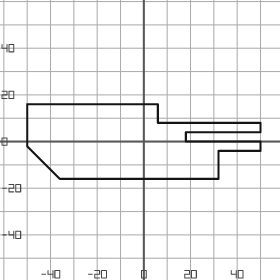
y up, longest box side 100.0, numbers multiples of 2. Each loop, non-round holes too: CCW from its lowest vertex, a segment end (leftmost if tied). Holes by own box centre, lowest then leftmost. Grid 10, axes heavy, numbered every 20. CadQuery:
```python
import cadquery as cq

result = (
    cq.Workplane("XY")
    .moveTo(-36.0, -16.0)
    .lineTo(32.0, -16.0)
    .lineTo(32.0, -4.0)
    .lineTo(50.0, -4.0)
    .lineTo(50.0, 0.0)
    .lineTo(18.0, 0.0)
    .lineTo(18.0, 4.0)
    .lineTo(50.0, 4.0)
    .lineTo(50.0, 8.0)
    .lineTo(6.0, 8.0)
    .lineTo(6.0, 16.0)
    .lineTo(-50.0, 16.0)
    .lineTo(-50.0, -2.0)
    .close()
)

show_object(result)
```